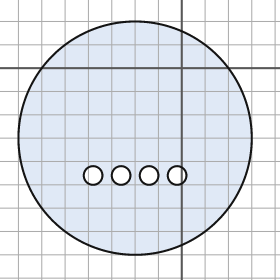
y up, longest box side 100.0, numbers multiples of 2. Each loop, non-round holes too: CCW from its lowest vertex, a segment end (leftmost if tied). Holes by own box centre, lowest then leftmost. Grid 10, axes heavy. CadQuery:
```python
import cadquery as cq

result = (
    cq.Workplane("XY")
    .moveTo(-20.0, -30.0)
    .circle(50.0)
    .moveTo(-38.0, -46.0)
    .circle(4.0)
    .moveTo(-26.0, -46.0)
    .circle(4.0)
    .moveTo(-14.0, -46.0)
    .circle(4.0)
    .moveTo(-2.0, -46.0)
    .circle(4.0)
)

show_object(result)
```